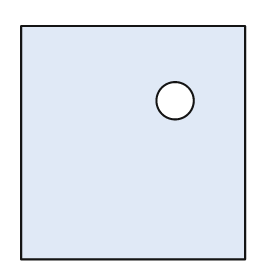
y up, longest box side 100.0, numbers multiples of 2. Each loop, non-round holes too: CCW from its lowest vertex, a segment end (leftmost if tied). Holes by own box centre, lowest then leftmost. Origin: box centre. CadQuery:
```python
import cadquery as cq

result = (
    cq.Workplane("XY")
    .moveTo(-48.0, -50.0)
    .lineTo(48.0, -50.0)
    .lineTo(48.0, 50.0)
    .lineTo(-48.0, 50.0)
    .close()
    .moveTo(18.0, 18.0)
    .circle(8.0)
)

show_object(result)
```